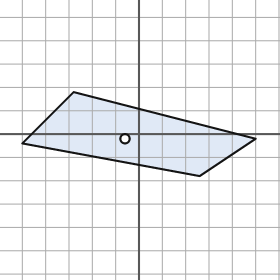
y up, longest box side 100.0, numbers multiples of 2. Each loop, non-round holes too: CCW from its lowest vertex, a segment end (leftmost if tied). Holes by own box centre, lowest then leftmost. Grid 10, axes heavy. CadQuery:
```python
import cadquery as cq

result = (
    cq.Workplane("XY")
    .moveTo(26.0, -18.0)
    .lineTo(50.0, -2.0)
    .lineTo(-28.0, 18.0)
    .lineTo(-50.0, -4.0)
    .close()
    .moveTo(-6.0, -2.0)
    .circle(2.0)
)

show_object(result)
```